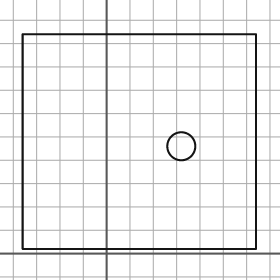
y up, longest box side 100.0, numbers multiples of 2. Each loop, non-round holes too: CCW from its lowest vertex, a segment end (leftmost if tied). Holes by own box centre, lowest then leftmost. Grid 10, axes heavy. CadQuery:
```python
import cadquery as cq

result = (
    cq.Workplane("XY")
    .moveTo(-36.0, 2.0)
    .lineTo(64.0, 2.0)
    .lineTo(64.0, 94.0)
    .lineTo(-36.0, 94.0)
    .close()
    .moveTo(32.0, 46.0)
    .circle(6.0)
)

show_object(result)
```